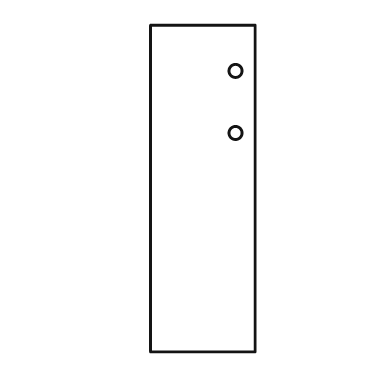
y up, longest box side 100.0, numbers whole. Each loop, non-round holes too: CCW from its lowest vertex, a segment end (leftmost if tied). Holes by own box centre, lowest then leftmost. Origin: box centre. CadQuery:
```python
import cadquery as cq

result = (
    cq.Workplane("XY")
    .moveTo(-16.0, -50.0)
    .lineTo(16.0, -50.0)
    .lineTo(16.0, 50.0)
    .lineTo(-16.0, 50.0)
    .close()
    .moveTo(10.0, 17.0)
    .circle(2.0)
    .moveTo(10.0, 36.0)
    .circle(2.0)
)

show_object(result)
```